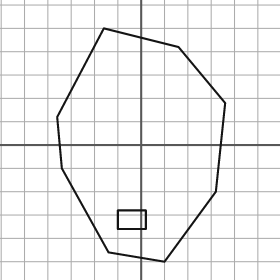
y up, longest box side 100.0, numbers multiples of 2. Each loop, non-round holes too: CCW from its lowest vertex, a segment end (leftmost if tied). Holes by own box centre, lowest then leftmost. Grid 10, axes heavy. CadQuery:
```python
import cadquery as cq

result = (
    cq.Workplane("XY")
    .moveTo(10.0, -50.0)
    .lineTo(32.0, -20.0)
    .lineTo(36.0, 18.0)
    .lineTo(16.0, 42.0)
    .lineTo(-16.0, 50.0)
    .lineTo(-36.0, 12.0)
    .lineTo(-34.0, -10.0)
    .lineTo(-14.0, -46.0)
    .close()
    .moveTo(-10.0, -36.0)
    .lineTo(2.0, -36.0)
    .lineTo(2.0, -28.0)
    .lineTo(-10.0, -28.0)
    .close()
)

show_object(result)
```